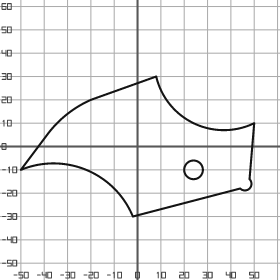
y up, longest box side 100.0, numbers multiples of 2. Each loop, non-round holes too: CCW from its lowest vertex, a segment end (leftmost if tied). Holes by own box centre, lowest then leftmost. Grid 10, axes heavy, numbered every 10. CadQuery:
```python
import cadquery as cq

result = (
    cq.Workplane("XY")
    .moveTo(-2.0, -30.0)
    .lineTo(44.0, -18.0)
    .threePointArc((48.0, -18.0), (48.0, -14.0))
    .lineTo(50.0, 10.0)
    .threePointArc((24.0, 10.0), (8.0, 30.0))
    .lineTo(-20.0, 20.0)
    .threePointArc((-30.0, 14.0), (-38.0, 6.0))
    .lineTo(-50.0, -10.0)
    .threePointArc((-22.0, -10.0), (-2.0, -30.0))
    .close()
    .moveTo(24.0, -10.0)
    .circle(4.0)
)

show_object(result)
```